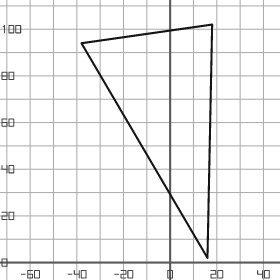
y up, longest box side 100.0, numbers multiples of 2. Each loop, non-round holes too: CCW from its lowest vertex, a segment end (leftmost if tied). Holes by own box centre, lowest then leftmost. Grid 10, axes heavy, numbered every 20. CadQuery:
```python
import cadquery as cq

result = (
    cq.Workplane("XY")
    .moveTo(16.0, 2.0)
    .lineTo(18.0, 102.0)
    .lineTo(-38.0, 94.0)
    .close()
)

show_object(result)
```